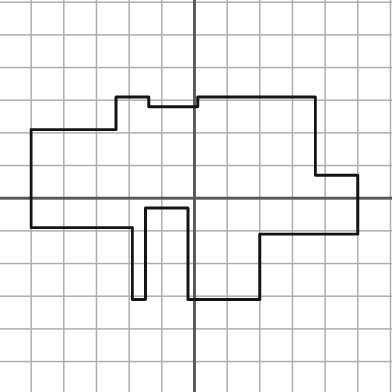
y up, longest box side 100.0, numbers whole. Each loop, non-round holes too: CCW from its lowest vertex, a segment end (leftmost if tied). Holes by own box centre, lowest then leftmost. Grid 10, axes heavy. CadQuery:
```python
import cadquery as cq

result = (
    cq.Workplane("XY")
    .moveTo(-19.0, -31.0)
    .lineTo(-15.0, -31.0)
    .lineTo(-15.0, -3.0)
    .lineTo(-2.0, -3.0)
    .lineTo(-2.0, -31.0)
    .lineTo(20.0, -31.0)
    .lineTo(20.0, -11.0)
    .lineTo(50.0, -11.0)
    .lineTo(50.0, 7.0)
    .lineTo(37.0, 7.0)
    .lineTo(37.0, 31.0)
    .lineTo(1.0, 31.0)
    .lineTo(1.0, 28.0)
    .lineTo(-14.0, 28.0)
    .lineTo(-14.0, 31.0)
    .lineTo(-24.0, 31.0)
    .lineTo(-24.0, 21.0)
    .lineTo(-50.0, 21.0)
    .lineTo(-50.0, -9.0)
    .lineTo(-19.0, -9.0)
    .close()
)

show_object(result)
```